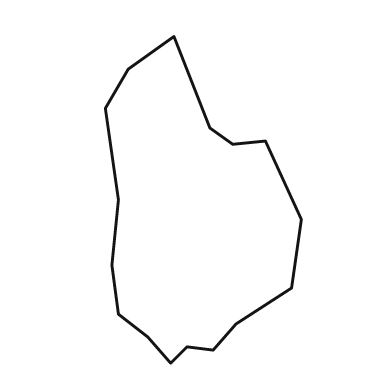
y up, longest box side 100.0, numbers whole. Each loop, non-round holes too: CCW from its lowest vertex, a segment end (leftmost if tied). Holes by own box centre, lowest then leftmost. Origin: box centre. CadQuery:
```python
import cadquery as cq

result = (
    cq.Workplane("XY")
    .moveTo(-10.0, -50.0)
    .lineTo(-5.0, -45.0)
    .lineTo(3.0, -46.0)
    .lineTo(10.0, -38.0)
    .lineTo(27.0, -27.0)
    .lineTo(30.0, -6.0)
    .lineTo(19.0, 18.0)
    .lineTo(9.0, 17.0)
    .lineTo(2.0, 22.0)
    .lineTo(-9.0, 50.0)
    .lineTo(-23.0, 40.0)
    .lineTo(-30.0, 28.0)
    .lineTo(-26.0, 0.0)
    .lineTo(-28.0, -20.0)
    .lineTo(-26.0, -35.0)
    .lineTo(-17.0, -42.0)
    .close()
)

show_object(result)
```